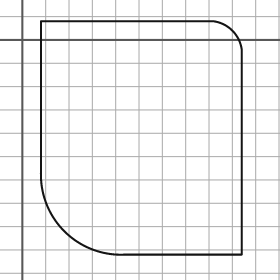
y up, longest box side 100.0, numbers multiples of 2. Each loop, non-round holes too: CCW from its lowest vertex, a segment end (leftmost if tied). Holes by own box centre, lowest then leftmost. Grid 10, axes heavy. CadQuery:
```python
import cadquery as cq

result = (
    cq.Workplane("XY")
    .moveTo(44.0, -92.0)
    .lineTo(94.0, -92.0)
    .lineTo(94.0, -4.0)
    .threePointArc((90.0, 4.0), (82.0, 8.0))
    .lineTo(8.0, 8.0)
    .lineTo(8.0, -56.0)
    .threePointArc((18.0, -82.0), (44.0, -92.0))
    .close()
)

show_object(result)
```